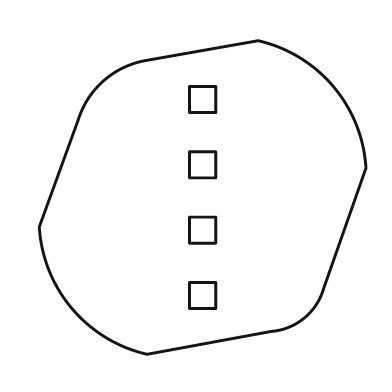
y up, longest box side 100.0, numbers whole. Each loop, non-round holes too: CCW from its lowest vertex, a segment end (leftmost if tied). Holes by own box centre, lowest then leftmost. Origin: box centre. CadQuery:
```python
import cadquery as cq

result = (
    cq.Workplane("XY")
    .moveTo(-17.0, -48.0)
    .lineTo(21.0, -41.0)
    .threePointArc((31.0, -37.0), (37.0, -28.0))
    .lineTo(50.0, 9.0)
    .threePointArc((40.0, 34.0), (17.0, 48.0))
    .lineTo(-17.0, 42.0)
    .threePointArc((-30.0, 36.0), (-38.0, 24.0))
    .lineTo(-50.0, -9.0)
    .threePointArc((-40.0, -34.0), (-17.0, -48.0))
    .close()
    .moveTo(-4.0, -34.0)
    .lineTo(4.0, -34.0)
    .lineTo(4.0, -26.0)
    .lineTo(-4.0, -26.0)
    .close()
    .moveTo(-4.0, -14.0)
    .lineTo(4.0, -14.0)
    .lineTo(4.0, -6.0)
    .lineTo(-4.0, -6.0)
    .close()
    .moveTo(-4.0, 6.0)
    .lineTo(4.0, 6.0)
    .lineTo(4.0, 14.0)
    .lineTo(-4.0, 14.0)
    .close()
    .moveTo(-4.0, 26.0)
    .lineTo(4.0, 26.0)
    .lineTo(4.0, 34.0)
    .lineTo(-4.0, 34.0)
    .close()
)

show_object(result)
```